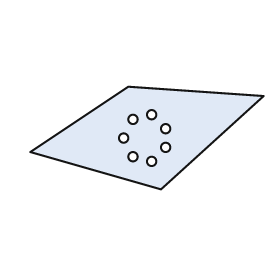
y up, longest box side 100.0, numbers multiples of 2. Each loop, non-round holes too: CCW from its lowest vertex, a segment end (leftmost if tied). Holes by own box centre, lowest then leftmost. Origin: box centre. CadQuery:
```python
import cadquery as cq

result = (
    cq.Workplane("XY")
    .moveTo(6.0, -22.0)
    .lineTo(50.0, 18.0)
    .lineTo(-8.0, 22.0)
    .lineTo(-50.0, -6.0)
    .close()
    .moveTo(2.0, -10.0)
    .circle(2.0)
    .moveTo(-6.0, -8.0)
    .circle(2.0)
    .moveTo(8.0, -4.0)
    .circle(2.0)
    .moveTo(-10.0, 0.0)
    .circle(2.0)
    .moveTo(8.0, 4.0)
    .circle(2.0)
    .moveTo(-6.0, 8.0)
    .circle(2.0)
    .moveTo(2.0, 10.0)
    .circle(2.0)
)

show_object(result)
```